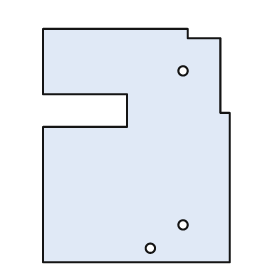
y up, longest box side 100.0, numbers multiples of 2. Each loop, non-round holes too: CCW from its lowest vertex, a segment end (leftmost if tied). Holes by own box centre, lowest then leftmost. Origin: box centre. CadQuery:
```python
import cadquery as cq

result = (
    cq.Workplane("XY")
    .moveTo(-40.0, -50.0)
    .lineTo(40.0, -50.0)
    .lineTo(40.0, 14.0)
    .lineTo(36.0, 14.0)
    .lineTo(36.0, 46.0)
    .lineTo(22.0, 46.0)
    .lineTo(22.0, 50.0)
    .lineTo(-40.0, 50.0)
    .lineTo(-40.0, 22.0)
    .lineTo(-4.0, 22.0)
    .lineTo(-4.0, 8.0)
    .lineTo(-40.0, 8.0)
    .close()
    .moveTo(6.0, -44.0)
    .circle(2.0)
    .moveTo(20.0, -34.0)
    .circle(2.0)
    .moveTo(20.0, 32.0)
    .circle(2.0)
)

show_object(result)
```